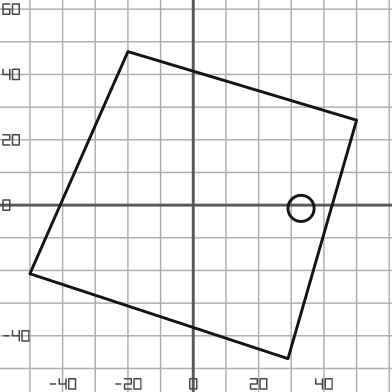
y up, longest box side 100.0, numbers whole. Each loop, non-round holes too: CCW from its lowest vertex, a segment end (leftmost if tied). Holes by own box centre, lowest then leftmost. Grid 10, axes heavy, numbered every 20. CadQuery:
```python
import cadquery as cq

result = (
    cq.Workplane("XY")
    .moveTo(29.0, -47.0)
    .lineTo(50.0, 26.0)
    .lineTo(-20.0, 47.0)
    .lineTo(-50.0, -21.0)
    .close()
    .moveTo(33.0, -1.0)
    .circle(4.0)
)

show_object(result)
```